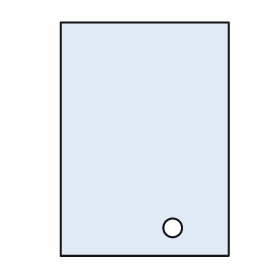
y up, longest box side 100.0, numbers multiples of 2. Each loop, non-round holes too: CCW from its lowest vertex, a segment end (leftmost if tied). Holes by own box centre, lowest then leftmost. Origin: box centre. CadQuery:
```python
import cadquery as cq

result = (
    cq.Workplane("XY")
    .moveTo(-36.0, -50.0)
    .lineTo(36.0, -50.0)
    .lineTo(36.0, 50.0)
    .lineTo(-36.0, 50.0)
    .close()
    .moveTo(12.0, -38.0)
    .circle(4.0)
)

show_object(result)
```